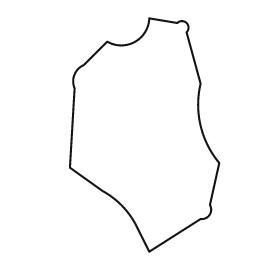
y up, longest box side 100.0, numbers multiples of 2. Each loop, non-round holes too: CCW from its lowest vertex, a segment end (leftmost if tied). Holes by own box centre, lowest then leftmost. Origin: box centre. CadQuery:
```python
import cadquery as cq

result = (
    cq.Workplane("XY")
    .moveTo(2.0, -50.0)
    .lineTo(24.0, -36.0)
    .threePointArc((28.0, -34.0), (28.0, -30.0))
    .lineTo(32.0, -12.0)
    .threePointArc((24.0, 4.0), (24.0, 22.0))
    .lineTo(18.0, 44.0)
    .threePointArc((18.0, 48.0), (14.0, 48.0))
    .lineTo(2.0, 50.0)
    .threePointArc((-4.0, 40.0), (-16.0, 40.0))
    .lineTo(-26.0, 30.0)
    .threePointArc((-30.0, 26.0), (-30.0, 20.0))
    .lineTo(-32.0, -14.0)
    .lineTo(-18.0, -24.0)
    .threePointArc((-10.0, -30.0), (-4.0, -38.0))
    .close()
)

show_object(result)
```